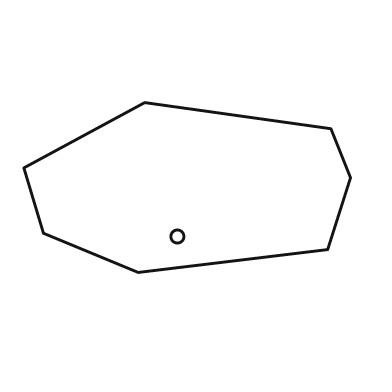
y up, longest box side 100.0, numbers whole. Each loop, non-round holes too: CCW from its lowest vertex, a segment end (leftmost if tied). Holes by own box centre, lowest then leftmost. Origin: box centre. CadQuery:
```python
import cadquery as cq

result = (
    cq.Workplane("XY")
    .moveTo(-15.0, -26.0)
    .lineTo(43.0, -19.0)
    .lineTo(50.0, 3.0)
    .lineTo(44.0, 18.0)
    .lineTo(-13.0, 26.0)
    .lineTo(-50.0, 6.0)
    .lineTo(-44.0, -14.0)
    .close()
    .moveTo(-3.0, -15.0)
    .circle(2.0)
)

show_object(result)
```